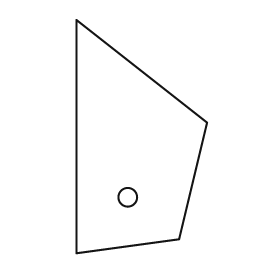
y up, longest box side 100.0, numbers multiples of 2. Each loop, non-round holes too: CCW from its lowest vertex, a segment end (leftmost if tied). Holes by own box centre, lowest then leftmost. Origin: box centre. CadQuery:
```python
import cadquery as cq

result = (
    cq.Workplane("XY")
    .moveTo(-28.0, -50.0)
    .lineTo(16.0, -44.0)
    .lineTo(28.0, 6.0)
    .lineTo(-28.0, 50.0)
    .close()
    .moveTo(-6.0, -26.0)
    .circle(4.0)
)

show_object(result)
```